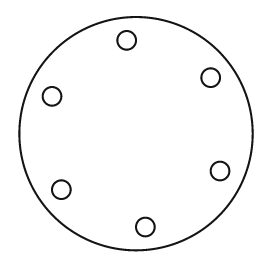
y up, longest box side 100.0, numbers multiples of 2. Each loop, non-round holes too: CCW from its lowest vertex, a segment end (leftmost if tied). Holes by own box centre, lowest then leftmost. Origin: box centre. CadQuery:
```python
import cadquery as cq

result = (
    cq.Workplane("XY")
    .moveTo(0.0, 0.0)
    .circle(50.0)
    .moveTo(4.0, -40.0)
    .circle(4.0)
    .moveTo(-32.0, -24.0)
    .circle(4.0)
    .moveTo(36.0, -16.0)
    .circle(4.0)
    .moveTo(-36.0, 16.0)
    .circle(4.0)
    .moveTo(32.0, 24.0)
    .circle(4.0)
    .moveTo(-4.0, 40.0)
    .circle(4.0)
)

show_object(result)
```